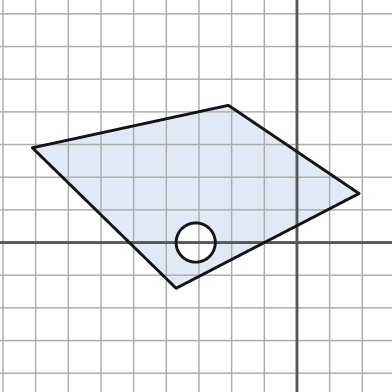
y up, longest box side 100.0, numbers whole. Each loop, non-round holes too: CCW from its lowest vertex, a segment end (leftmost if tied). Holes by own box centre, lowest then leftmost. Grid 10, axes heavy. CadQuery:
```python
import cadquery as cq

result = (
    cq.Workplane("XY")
    .moveTo(-37.0, -14.0)
    .lineTo(19.0, 15.0)
    .lineTo(-21.0, 42.0)
    .lineTo(-81.0, 29.0)
    .close()
    .moveTo(-31.0, 0.0)
    .circle(6.0)
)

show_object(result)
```